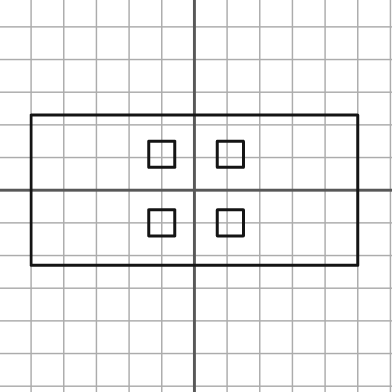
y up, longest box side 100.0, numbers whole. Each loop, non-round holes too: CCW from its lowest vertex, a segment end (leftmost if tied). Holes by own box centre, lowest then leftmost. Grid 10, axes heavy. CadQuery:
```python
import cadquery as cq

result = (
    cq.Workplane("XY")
    .moveTo(-50.0, -23.0)
    .lineTo(50.0, -23.0)
    .lineTo(50.0, 23.0)
    .lineTo(-50.0, 23.0)
    .close()
    .moveTo(-14.0, -14.0)
    .lineTo(-6.0, -14.0)
    .lineTo(-6.0, -6.0)
    .lineTo(-14.0, -6.0)
    .close()
    .moveTo(7.0, -14.0)
    .lineTo(15.0, -14.0)
    .lineTo(15.0, -6.0)
    .lineTo(7.0, -6.0)
    .close()
    .moveTo(-14.0, 7.0)
    .lineTo(-6.0, 7.0)
    .lineTo(-6.0, 15.0)
    .lineTo(-14.0, 15.0)
    .close()
    .moveTo(7.0, 7.0)
    .lineTo(15.0, 7.0)
    .lineTo(15.0, 15.0)
    .lineTo(7.0, 15.0)
    .close()
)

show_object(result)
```